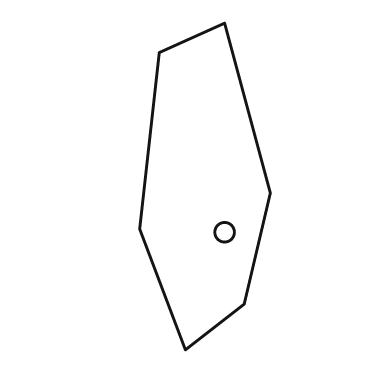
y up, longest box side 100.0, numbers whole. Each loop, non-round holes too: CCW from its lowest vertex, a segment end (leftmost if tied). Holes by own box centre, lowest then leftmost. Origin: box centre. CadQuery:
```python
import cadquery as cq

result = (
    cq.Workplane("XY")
    .moveTo(-6.0, -50.0)
    .lineTo(12.0, -36.0)
    .lineTo(20.0, -2.0)
    .lineTo(6.0, 50.0)
    .lineTo(-14.0, 41.0)
    .lineTo(-20.0, -13.0)
    .close()
    .moveTo(6.0, -14.0)
    .circle(3.0)
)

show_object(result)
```